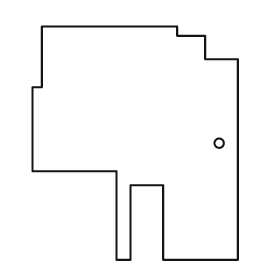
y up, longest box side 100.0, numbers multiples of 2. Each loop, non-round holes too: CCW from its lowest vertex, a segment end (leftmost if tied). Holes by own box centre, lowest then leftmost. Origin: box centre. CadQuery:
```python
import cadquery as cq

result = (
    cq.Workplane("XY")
    .moveTo(-8.0, -50.0)
    .lineTo(-2.0, -50.0)
    .lineTo(-2.0, -18.0)
    .lineTo(12.0, -18.0)
    .lineTo(12.0, -50.0)
    .lineTo(44.0, -50.0)
    .lineTo(44.0, 36.0)
    .lineTo(30.0, 36.0)
    .lineTo(30.0, 46.0)
    .lineTo(18.0, 46.0)
    .lineTo(18.0, 50.0)
    .lineTo(-40.0, 50.0)
    .lineTo(-40.0, 24.0)
    .lineTo(-44.0, 24.0)
    .lineTo(-44.0, -12.0)
    .lineTo(-8.0, -12.0)
    .close()
    .moveTo(36.0, 0.0)
    .circle(2.0)
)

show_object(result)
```